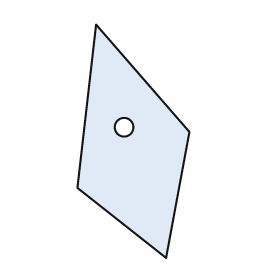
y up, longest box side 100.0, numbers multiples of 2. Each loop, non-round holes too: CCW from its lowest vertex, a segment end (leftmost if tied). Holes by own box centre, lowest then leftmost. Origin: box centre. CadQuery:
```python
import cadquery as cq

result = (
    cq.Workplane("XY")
    .moveTo(14.0, -50.0)
    .lineTo(24.0, 4.0)
    .lineTo(-16.0, 50.0)
    .lineTo(-24.0, -20.0)
    .close()
    .moveTo(-4.0, 6.0)
    .circle(4.0)
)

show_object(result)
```